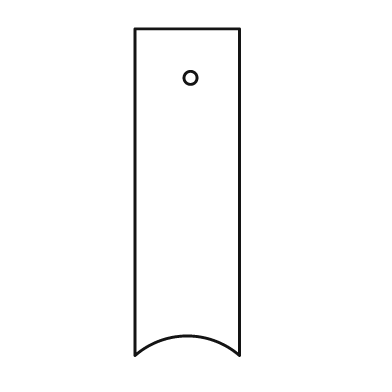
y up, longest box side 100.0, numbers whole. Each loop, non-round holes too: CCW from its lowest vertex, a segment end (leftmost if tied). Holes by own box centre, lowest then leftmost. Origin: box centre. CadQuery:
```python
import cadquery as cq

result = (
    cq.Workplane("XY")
    .moveTo(-16.0, -50.0)
    .threePointArc((0.0, -44.0), (16.0, -50.0))
    .lineTo(16.0, 50.0)
    .lineTo(-16.0, 50.0)
    .close()
    .moveTo(1.0, 35.0)
    .circle(2.0)
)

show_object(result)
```